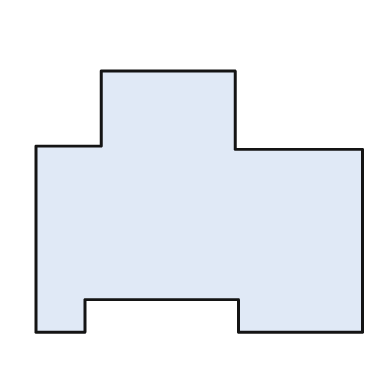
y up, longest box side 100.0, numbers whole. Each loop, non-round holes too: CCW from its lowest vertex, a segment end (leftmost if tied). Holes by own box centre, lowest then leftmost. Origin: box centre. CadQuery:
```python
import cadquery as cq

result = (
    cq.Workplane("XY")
    .moveTo(-50.0, -40.0)
    .lineTo(-35.0, -40.0)
    .lineTo(-35.0, -30.0)
    .lineTo(12.0, -30.0)
    .lineTo(12.0, -40.0)
    .lineTo(50.0, -40.0)
    .lineTo(50.0, 16.0)
    .lineTo(11.0, 16.0)
    .lineTo(11.0, 40.0)
    .lineTo(-30.0, 40.0)
    .lineTo(-30.0, 17.0)
    .lineTo(-50.0, 17.0)
    .close()
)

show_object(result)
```